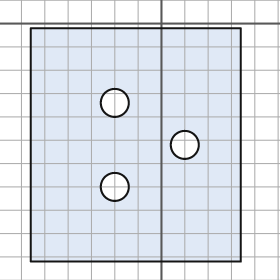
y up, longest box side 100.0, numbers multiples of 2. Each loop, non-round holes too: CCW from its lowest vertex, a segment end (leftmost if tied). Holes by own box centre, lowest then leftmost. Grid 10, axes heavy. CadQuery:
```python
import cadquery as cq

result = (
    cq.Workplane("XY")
    .moveTo(-56.0, -102.0)
    .lineTo(34.0, -102.0)
    .lineTo(34.0, -2.0)
    .lineTo(-56.0, -2.0)
    .close()
    .moveTo(-20.0, -70.0)
    .circle(6.0)
    .moveTo(10.0, -52.0)
    .circle(6.0)
    .moveTo(-20.0, -34.0)
    .circle(6.0)
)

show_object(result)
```